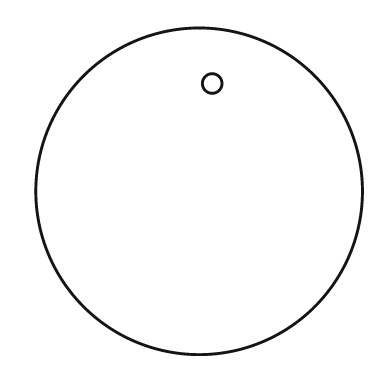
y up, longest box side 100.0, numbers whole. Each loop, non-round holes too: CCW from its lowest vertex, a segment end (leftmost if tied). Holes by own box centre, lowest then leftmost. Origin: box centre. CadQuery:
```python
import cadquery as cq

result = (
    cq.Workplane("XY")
    .moveTo(0.0, 0.0)
    .circle(50.0)
    .moveTo(4.0, 33.0)
    .circle(3.0)
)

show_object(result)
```